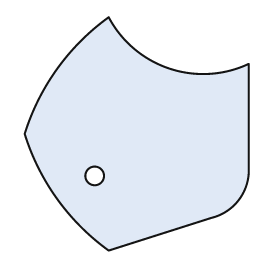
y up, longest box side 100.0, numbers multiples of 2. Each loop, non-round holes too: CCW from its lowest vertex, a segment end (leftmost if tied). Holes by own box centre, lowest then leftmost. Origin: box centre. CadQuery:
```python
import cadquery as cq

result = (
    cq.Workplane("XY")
    .moveTo(-12.0, -50.0)
    .lineTo(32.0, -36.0)
    .threePointArc((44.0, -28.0), (48.0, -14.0))
    .lineTo(48.0, 30.0)
    .threePointArc((14.0, 28.0), (-12.0, 50.0))
    .threePointArc((-34.0, 28.0), (-48.0, 0.0))
    .threePointArc((-34.0, -28.0), (-12.0, -50.0))
    .close()
    .moveTo(-18.0, -18.0)
    .circle(4.0)
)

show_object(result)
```